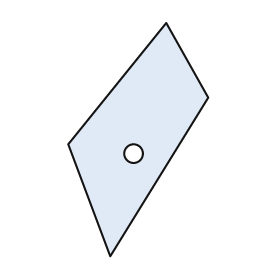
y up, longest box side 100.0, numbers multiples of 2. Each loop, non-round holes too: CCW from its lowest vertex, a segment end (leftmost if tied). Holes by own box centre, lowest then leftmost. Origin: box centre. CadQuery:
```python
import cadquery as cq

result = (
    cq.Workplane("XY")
    .moveTo(-12.0, -50.0)
    .lineTo(30.0, 18.0)
    .lineTo(12.0, 50.0)
    .lineTo(-30.0, -2.0)
    .close()
    .moveTo(-2.0, -6.0)
    .circle(4.0)
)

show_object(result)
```